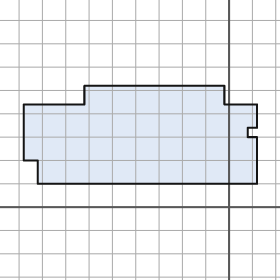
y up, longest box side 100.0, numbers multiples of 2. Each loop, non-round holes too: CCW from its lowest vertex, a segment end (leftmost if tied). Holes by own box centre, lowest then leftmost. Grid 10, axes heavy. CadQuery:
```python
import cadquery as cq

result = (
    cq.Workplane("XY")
    .moveTo(-82.0, 10.0)
    .lineTo(12.0, 10.0)
    .lineTo(12.0, 30.0)
    .lineTo(8.0, 30.0)
    .lineTo(8.0, 34.0)
    .lineTo(12.0, 34.0)
    .lineTo(12.0, 44.0)
    .lineTo(-2.0, 44.0)
    .lineTo(-2.0, 52.0)
    .lineTo(-62.0, 52.0)
    .lineTo(-62.0, 44.0)
    .lineTo(-88.0, 44.0)
    .lineTo(-88.0, 20.0)
    .lineTo(-82.0, 20.0)
    .close()
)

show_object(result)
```